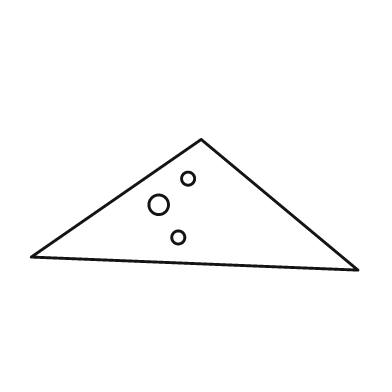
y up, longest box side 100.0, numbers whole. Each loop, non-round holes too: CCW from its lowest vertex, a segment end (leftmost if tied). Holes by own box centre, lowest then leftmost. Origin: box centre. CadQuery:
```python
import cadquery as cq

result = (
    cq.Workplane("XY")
    .moveTo(50.0, -20.0)
    .lineTo(2.0, 20.0)
    .lineTo(-50.0, -16.0)
    .close()
    .moveTo(-5.0, -10.0)
    .circle(2.0)
    .moveTo(-11.0, 0.0)
    .circle(3.0)
    .moveTo(-2.0, 8.0)
    .circle(2.0)
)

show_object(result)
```